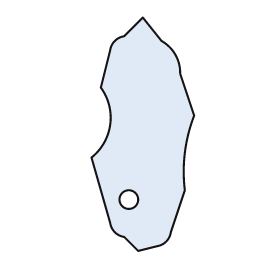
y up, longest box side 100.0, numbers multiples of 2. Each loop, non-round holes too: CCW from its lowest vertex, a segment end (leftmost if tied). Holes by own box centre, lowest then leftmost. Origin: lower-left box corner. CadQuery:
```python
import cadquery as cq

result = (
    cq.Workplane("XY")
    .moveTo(20.0, 0.0)
    .lineTo(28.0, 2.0)
    .threePointArc((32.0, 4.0), (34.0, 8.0))
    .lineTo(40.0, 26.0)
    .threePointArc((40.0, 42.0), (44.0, 58.0))
    .lineTo(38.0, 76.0)
    .threePointArc((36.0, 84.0), (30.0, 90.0))
    .lineTo(22.0, 100.0)
    .lineTo(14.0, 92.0)
    .threePointArc((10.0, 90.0), (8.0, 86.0))
    .lineTo(4.0, 70.0)
    .threePointArc((8.0, 54.0), (0.0, 40.0))
    .lineTo(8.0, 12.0)
    .threePointArc((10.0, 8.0), (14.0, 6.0))
    .close()
    .moveTo(16.0, 22.0)
    .circle(4.0)
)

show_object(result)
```